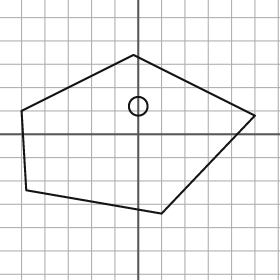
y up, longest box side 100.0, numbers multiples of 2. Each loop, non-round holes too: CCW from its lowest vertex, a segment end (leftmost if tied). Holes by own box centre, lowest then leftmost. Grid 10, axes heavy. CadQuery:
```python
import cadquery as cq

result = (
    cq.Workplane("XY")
    .moveTo(10.0, -34.0)
    .lineTo(50.0, 8.0)
    .lineTo(-2.0, 34.0)
    .lineTo(-50.0, 10.0)
    .lineTo(-48.0, -24.0)
    .close()
    .moveTo(0.0, 12.0)
    .circle(4.0)
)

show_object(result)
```